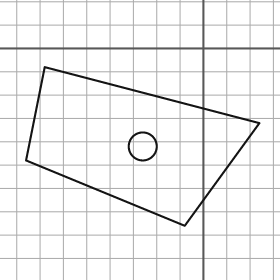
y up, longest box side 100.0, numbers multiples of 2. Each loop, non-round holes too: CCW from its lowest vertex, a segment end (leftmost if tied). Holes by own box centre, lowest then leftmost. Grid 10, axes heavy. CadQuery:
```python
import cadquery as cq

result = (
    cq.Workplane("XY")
    .moveTo(-8.0, -76.0)
    .lineTo(24.0, -32.0)
    .lineTo(-68.0, -8.0)
    .lineTo(-76.0, -48.0)
    .close()
    .moveTo(-26.0, -42.0)
    .circle(6.0)
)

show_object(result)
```